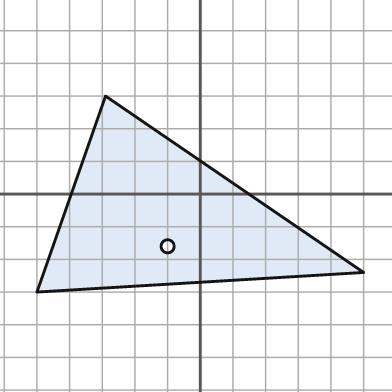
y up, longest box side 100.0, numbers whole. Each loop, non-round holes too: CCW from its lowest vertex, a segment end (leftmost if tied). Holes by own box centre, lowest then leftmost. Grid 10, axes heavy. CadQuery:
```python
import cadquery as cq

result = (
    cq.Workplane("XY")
    .moveTo(-50.0, -30.0)
    .lineTo(50.0, -24.0)
    .lineTo(-29.0, 30.0)
    .close()
    .moveTo(-10.0, -16.0)
    .circle(2.0)
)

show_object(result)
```